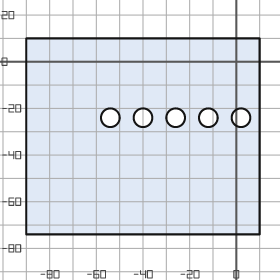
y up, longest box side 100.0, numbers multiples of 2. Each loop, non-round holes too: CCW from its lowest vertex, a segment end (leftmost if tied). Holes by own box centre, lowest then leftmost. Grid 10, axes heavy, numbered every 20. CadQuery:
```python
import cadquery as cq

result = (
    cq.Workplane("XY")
    .moveTo(-90.0, -74.0)
    .lineTo(10.0, -74.0)
    .lineTo(10.0, 10.0)
    .lineTo(-90.0, 10.0)
    .close()
    .moveTo(-54.0, -24.0)
    .circle(4.0)
    .moveTo(-40.0, -24.0)
    .circle(4.0)
    .moveTo(-26.0, -24.0)
    .circle(4.0)
    .moveTo(-12.0, -24.0)
    .circle(4.0)
    .moveTo(2.0, -24.0)
    .circle(4.0)
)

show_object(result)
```